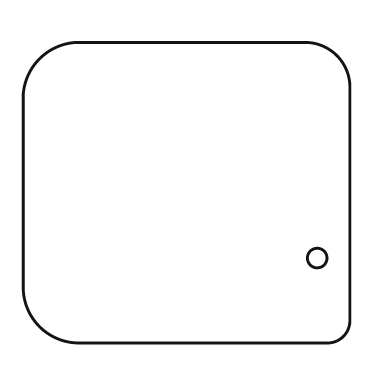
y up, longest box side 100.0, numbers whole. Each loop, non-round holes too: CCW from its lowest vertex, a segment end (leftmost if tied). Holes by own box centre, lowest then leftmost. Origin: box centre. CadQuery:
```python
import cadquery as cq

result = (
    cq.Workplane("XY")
    .moveTo(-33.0, -46.0)
    .lineTo(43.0, -46.0)
    .threePointArc((48.0, -44.0), (50.0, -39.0))
    .lineTo(50.0, 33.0)
    .threePointArc((46.0, 42.0), (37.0, 46.0))
    .lineTo(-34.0, 46.0)
    .threePointArc((-45.0, 41.0), (-50.0, 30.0))
    .lineTo(-50.0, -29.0)
    .threePointArc((-45.0, -41.0), (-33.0, -46.0))
    .close()
    .moveTo(40.0, -20.0)
    .circle(3.0)
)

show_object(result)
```